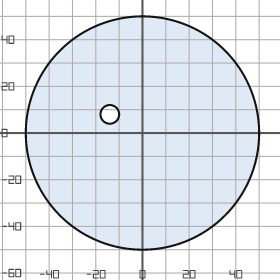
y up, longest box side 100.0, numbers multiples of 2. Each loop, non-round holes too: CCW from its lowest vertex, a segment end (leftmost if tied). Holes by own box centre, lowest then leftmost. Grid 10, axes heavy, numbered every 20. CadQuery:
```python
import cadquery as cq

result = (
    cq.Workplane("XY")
    .moveTo(0.0, 0.0)
    .circle(50.0)
    .moveTo(-14.0, 8.0)
    .circle(4.0)
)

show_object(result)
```